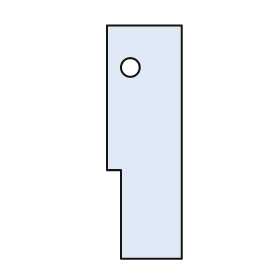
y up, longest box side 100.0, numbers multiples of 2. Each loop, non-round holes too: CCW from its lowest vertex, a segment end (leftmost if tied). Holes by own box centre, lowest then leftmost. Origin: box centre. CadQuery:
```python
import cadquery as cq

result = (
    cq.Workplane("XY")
    .moveTo(-10.0, -50.0)
    .lineTo(16.0, -50.0)
    .lineTo(16.0, 50.0)
    .lineTo(-16.0, 50.0)
    .lineTo(-16.0, -12.0)
    .lineTo(-10.0, -12.0)
    .close()
    .moveTo(-6.0, 32.0)
    .circle(4.0)
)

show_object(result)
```